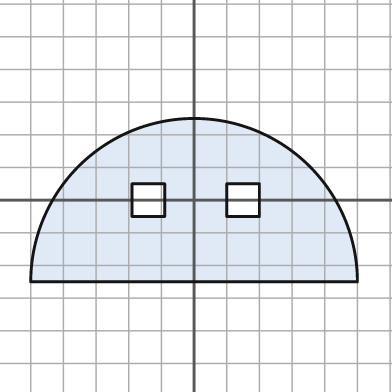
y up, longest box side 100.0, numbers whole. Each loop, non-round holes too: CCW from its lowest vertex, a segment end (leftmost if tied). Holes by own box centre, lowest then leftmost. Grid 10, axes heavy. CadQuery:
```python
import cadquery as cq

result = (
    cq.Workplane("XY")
    .moveTo(-50.0, -25.0)
    .lineTo(50.0, -25.0)
    .threePointArc((0.0, 25.0), (-50.0, -25.0))
    .close()
    .moveTo(-19.0, -5.0)
    .lineTo(-9.0, -5.0)
    .lineTo(-9.0, 5.0)
    .lineTo(-19.0, 5.0)
    .close()
    .moveTo(10.0, -5.0)
    .lineTo(20.0, -5.0)
    .lineTo(20.0, 5.0)
    .lineTo(10.0, 5.0)
    .close()
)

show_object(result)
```